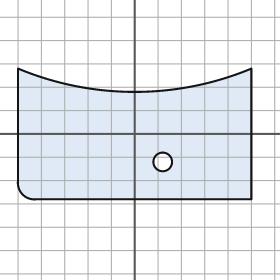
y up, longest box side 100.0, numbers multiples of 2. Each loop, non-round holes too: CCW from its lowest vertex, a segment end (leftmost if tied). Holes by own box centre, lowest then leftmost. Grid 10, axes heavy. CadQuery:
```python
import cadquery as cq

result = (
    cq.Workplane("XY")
    .moveTo(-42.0, -28.0)
    .lineTo(50.0, -28.0)
    .lineTo(50.0, 28.0)
    .threePointArc((0.0, 18.0), (-50.0, 28.0))
    .lineTo(-50.0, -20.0)
    .threePointArc((-48.0, -26.0), (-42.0, -28.0))
    .close()
    .moveTo(12.0, -12.0)
    .circle(4.0)
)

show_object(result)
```